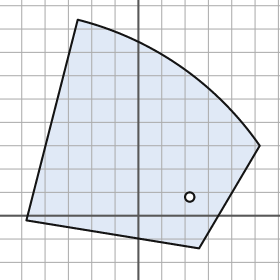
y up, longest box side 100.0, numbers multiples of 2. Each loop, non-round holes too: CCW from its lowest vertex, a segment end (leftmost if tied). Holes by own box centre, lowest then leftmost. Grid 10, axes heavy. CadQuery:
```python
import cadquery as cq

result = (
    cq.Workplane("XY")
    .moveTo(26.0, -14.0)
    .lineTo(52.0, 30.0)
    .threePointArc((18.0, 64.0), (-26.0, 84.0))
    .lineTo(-48.0, -2.0)
    .close()
    .moveTo(22.0, 8.0)
    .circle(2.0)
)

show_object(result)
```